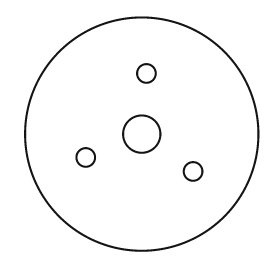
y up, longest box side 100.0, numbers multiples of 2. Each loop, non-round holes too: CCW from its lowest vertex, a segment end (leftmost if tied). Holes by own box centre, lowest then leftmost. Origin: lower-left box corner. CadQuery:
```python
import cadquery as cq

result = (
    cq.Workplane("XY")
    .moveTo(50.0, 50.0)
    .circle(50.0)
    .moveTo(72.0, 34.0)
    .circle(4.0)
    .moveTo(26.0, 40.0)
    .circle(4.0)
    .moveTo(50.0, 50.0)
    .circle(8.0)
    .moveTo(52.0, 76.0)
    .circle(4.0)
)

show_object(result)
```